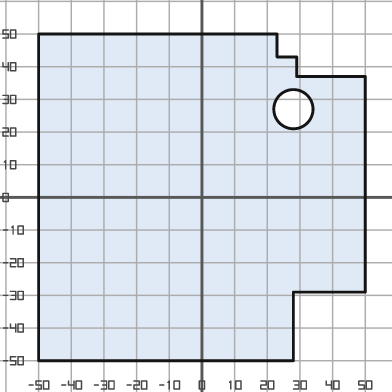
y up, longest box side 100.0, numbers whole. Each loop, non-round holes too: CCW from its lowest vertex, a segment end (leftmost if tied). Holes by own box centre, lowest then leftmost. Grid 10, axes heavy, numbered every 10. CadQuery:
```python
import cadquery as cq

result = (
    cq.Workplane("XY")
    .moveTo(-50.0, -50.0)
    .lineTo(28.0, -50.0)
    .lineTo(28.0, -29.0)
    .lineTo(50.0, -29.0)
    .lineTo(50.0, 37.0)
    .lineTo(29.0, 37.0)
    .lineTo(29.0, 43.0)
    .lineTo(23.0, 43.0)
    .lineTo(23.0, 50.0)
    .lineTo(-50.0, 50.0)
    .close()
    .moveTo(28.0, 27.0)
    .circle(6.0)
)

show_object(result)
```